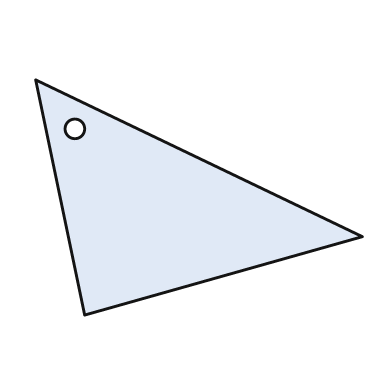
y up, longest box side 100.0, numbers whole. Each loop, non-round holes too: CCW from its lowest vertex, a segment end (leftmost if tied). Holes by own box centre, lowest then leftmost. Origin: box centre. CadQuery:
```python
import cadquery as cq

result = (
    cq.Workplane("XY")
    .moveTo(-35.0, -36.0)
    .lineTo(50.0, -12.0)
    .lineTo(-50.0, 36.0)
    .close()
    .moveTo(-38.0, 21.0)
    .circle(3.0)
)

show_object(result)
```